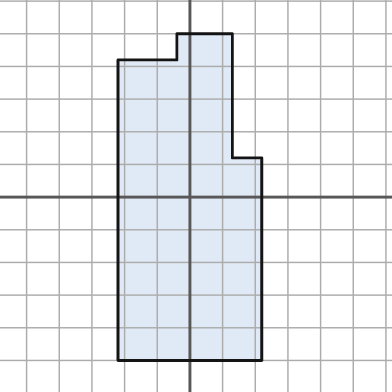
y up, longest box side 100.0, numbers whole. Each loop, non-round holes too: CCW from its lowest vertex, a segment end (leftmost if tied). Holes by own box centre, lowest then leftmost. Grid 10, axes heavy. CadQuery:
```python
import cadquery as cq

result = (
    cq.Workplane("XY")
    .moveTo(-22.0, -50.0)
    .lineTo(22.0, -50.0)
    .lineTo(22.0, 12.0)
    .lineTo(13.0, 12.0)
    .lineTo(13.0, 50.0)
    .lineTo(-4.0, 50.0)
    .lineTo(-4.0, 42.0)
    .lineTo(-22.0, 42.0)
    .close()
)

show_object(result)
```